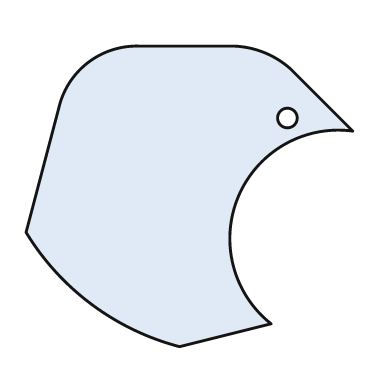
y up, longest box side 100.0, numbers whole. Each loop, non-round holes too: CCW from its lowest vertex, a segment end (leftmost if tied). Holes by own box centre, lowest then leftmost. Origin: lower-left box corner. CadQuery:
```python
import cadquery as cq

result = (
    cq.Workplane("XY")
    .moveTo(47.0, 0.0)
    .lineTo(75.0, 7.0)
    .threePointArc((65.0, 46.0), (100.0, 66.0))
    .lineTo(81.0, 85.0)
    .threePointArc((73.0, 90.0), (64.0, 92.0))
    .lineTo(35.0, 92.0)
    .threePointArc((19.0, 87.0), (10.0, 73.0))
    .lineTo(0.0, 35.0)
    .threePointArc((20.0, 13.0), (47.0, 0.0))
    .close()
    .moveTo(80.0, 70.0)
    .circle(3.0)
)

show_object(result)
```